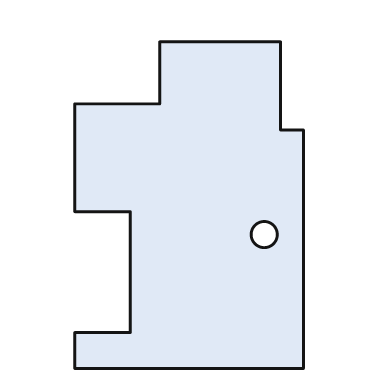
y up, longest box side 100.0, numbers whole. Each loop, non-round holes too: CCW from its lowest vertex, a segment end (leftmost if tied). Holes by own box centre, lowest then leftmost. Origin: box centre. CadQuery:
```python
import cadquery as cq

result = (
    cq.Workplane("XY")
    .moveTo(-35.0, -50.0)
    .lineTo(35.0, -50.0)
    .lineTo(35.0, 23.0)
    .lineTo(28.0, 23.0)
    .lineTo(28.0, 50.0)
    .lineTo(-9.0, 50.0)
    .lineTo(-9.0, 31.0)
    .lineTo(-35.0, 31.0)
    .lineTo(-35.0, -2.0)
    .lineTo(-18.0, -2.0)
    .lineTo(-18.0, -39.0)
    .lineTo(-35.0, -39.0)
    .close()
    .moveTo(23.0, -9.0)
    .circle(4.0)
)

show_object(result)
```